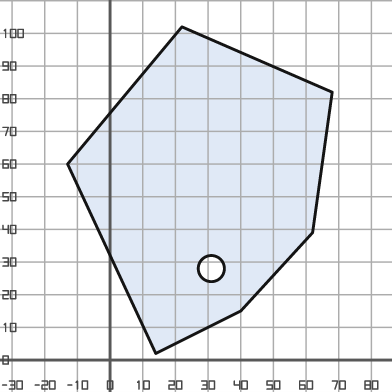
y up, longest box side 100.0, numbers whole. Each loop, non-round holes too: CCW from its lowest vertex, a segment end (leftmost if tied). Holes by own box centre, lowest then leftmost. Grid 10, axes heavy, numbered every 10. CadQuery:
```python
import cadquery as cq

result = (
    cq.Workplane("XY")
    .moveTo(14.0, 2.0)
    .lineTo(40.0, 15.0)
    .lineTo(62.0, 39.0)
    .lineTo(68.0, 82.0)
    .lineTo(22.0, 102.0)
    .lineTo(-13.0, 60.0)
    .close()
    .moveTo(31.0, 28.0)
    .circle(4.0)
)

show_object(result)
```